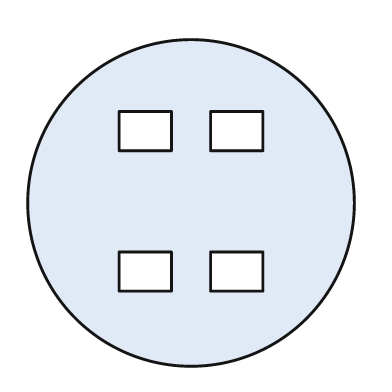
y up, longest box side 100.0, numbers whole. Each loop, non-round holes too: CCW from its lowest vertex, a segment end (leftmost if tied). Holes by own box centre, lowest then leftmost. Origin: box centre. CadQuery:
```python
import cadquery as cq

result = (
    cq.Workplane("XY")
    .moveTo(0.0, 0.0)
    .circle(50.0)
    .moveTo(-22.0, -27.0)
    .lineTo(-6.0, -27.0)
    .lineTo(-6.0, -15.0)
    .lineTo(-22.0, -15.0)
    .close()
    .moveTo(6.0, -27.0)
    .lineTo(22.0, -27.0)
    .lineTo(22.0, -15.0)
    .lineTo(6.0, -15.0)
    .close()
    .moveTo(-22.0, 16.0)
    .lineTo(-6.0, 16.0)
    .lineTo(-6.0, 28.0)
    .lineTo(-22.0, 28.0)
    .close()
    .moveTo(6.0, 16.0)
    .lineTo(22.0, 16.0)
    .lineTo(22.0, 28.0)
    .lineTo(6.0, 28.0)
    .close()
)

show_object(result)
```